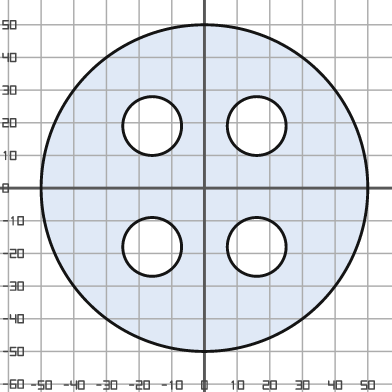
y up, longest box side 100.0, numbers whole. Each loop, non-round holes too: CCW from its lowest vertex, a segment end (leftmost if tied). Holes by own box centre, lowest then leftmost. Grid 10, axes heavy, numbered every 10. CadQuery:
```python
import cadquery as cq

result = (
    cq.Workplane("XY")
    .moveTo(0.0, 0.0)
    .circle(50.0)
    .moveTo(-16.0, -18.0)
    .circle(9.0)
    .moveTo(16.0, -18.0)
    .circle(9.0)
    .moveTo(-16.0, 19.0)
    .circle(9.0)
    .moveTo(16.0, 19.0)
    .circle(9.0)
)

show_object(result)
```